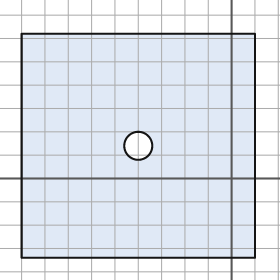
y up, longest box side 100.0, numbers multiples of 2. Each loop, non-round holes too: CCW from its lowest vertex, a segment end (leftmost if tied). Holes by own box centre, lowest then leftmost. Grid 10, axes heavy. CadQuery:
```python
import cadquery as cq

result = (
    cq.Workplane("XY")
    .moveTo(-90.0, -34.0)
    .lineTo(10.0, -34.0)
    .lineTo(10.0, 62.0)
    .lineTo(-90.0, 62.0)
    .close()
    .moveTo(-40.0, 14.0)
    .circle(6.0)
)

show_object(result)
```